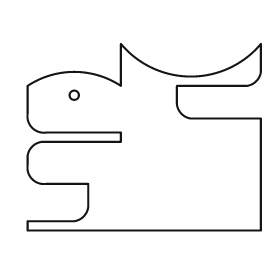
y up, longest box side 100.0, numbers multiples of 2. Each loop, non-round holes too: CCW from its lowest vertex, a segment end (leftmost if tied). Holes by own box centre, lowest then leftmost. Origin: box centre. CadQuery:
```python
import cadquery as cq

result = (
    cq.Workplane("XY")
    .moveTo(-50.0, -40.0)
    .lineTo(50.0, -40.0)
    .lineTo(50.0, 8.0)
    .lineTo(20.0, 8.0)
    .threePointArc((16.0, 10.0), (14.0, 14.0))
    .lineTo(14.0, 22.0)
    .lineTo(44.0, 22.0)
    .threePointArc((48.0, 24.0), (50.0, 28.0))
    .lineTo(50.0, 40.0)
    .threePointArc((20.0, 26.0), (-10.0, 40.0))
    .lineTo(-10.0, 22.0)
    .threePointArc((-30.0, 28.0), (-50.0, 22.0))
    .lineTo(-50.0, 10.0)
    .threePointArc((-48.0, 4.0), (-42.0, 2.0))
    .lineTo(-10.0, 2.0)
    .lineTo(-10.0, -2.0)
    .lineTo(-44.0, -2.0)
    .threePointArc((-48.0, -4.0), (-50.0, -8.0))
    .lineTo(-50.0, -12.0)
    .threePointArc((-48.0, -18.0), (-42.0, -20.0))
    .lineTo(-24.0, -20.0)
    .lineTo(-24.0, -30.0)
    .threePointArc((-26.0, -34.0), (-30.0, -36.0))
    .lineTo(-50.0, -36.0)
    .close()
    .moveTo(-30.0, 18.0)
    .circle(2.0)
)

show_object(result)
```